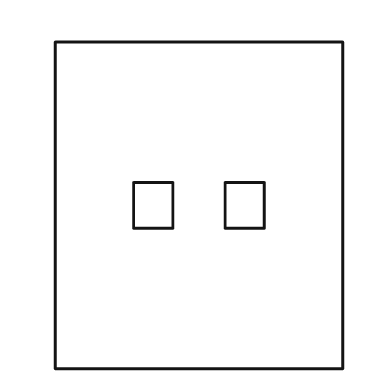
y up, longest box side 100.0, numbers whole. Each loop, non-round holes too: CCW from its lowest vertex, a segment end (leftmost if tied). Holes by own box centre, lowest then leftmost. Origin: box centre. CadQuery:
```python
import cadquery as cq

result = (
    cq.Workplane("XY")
    .moveTo(-44.0, -50.0)
    .lineTo(44.0, -50.0)
    .lineTo(44.0, 50.0)
    .lineTo(-44.0, 50.0)
    .close()
    .moveTo(-20.0, -7.0)
    .lineTo(-8.0, -7.0)
    .lineTo(-8.0, 7.0)
    .lineTo(-20.0, 7.0)
    .close()
    .moveTo(8.0, -7.0)
    .lineTo(20.0, -7.0)
    .lineTo(20.0, 7.0)
    .lineTo(8.0, 7.0)
    .close()
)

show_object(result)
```